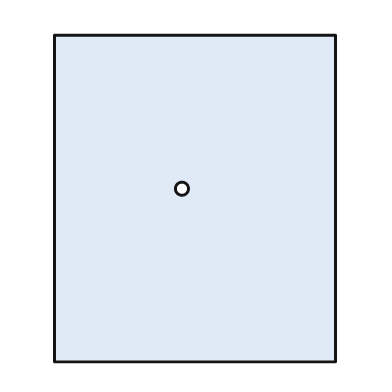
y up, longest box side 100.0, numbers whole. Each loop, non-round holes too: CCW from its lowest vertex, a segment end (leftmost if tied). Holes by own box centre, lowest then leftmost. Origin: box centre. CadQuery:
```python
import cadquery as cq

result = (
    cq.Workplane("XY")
    .moveTo(-43.0, -50.0)
    .lineTo(43.0, -50.0)
    .lineTo(43.0, 50.0)
    .lineTo(-43.0, 50.0)
    .close()
    .moveTo(-4.0, 3.0)
    .circle(2.0)
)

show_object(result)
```